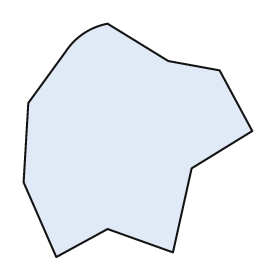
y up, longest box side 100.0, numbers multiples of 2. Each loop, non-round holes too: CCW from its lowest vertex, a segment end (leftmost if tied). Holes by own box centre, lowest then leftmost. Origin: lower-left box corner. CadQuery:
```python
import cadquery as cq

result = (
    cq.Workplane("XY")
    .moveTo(14.0, 0.0)
    .lineTo(36.0, 12.0)
    .lineTo(64.0, 2.0)
    .lineTo(72.0, 38.0)
    .lineTo(98.0, 54.0)
    .lineTo(84.0, 80.0)
    .lineTo(62.0, 84.0)
    .lineTo(36.0, 100.0)
    .threePointArc((26.0, 96.0), (18.0, 88.0))
    .lineTo(2.0, 66.0)
    .lineTo(0.0, 32.0)
    .close()
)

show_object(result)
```